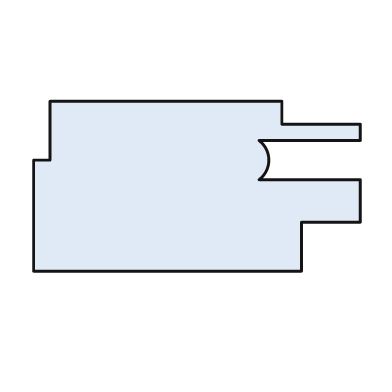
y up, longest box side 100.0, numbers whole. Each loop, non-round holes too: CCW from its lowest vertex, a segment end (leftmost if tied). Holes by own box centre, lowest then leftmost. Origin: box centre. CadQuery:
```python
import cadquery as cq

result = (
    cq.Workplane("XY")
    .moveTo(-50.0, -26.0)
    .lineTo(32.0, -26.0)
    .lineTo(32.0, -11.0)
    .lineTo(50.0, -11.0)
    .lineTo(50.0, 2.0)
    .lineTo(19.0, 2.0)
    .threePointArc((22.0, 8.0), (19.0, 14.0))
    .lineTo(50.0, 14.0)
    .lineTo(50.0, 19.0)
    .lineTo(26.0, 19.0)
    .lineTo(26.0, 26.0)
    .lineTo(-45.0, 26.0)
    .lineTo(-45.0, 8.0)
    .lineTo(-50.0, 8.0)
    .close()
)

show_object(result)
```